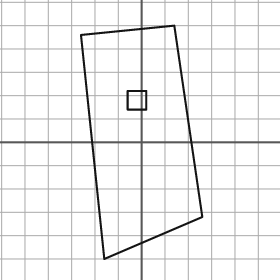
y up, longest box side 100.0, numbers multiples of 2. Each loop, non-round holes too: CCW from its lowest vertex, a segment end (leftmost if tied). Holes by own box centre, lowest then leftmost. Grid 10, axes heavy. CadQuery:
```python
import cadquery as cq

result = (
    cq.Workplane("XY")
    .moveTo(-16.0, -50.0)
    .lineTo(26.0, -32.0)
    .lineTo(14.0, 50.0)
    .lineTo(-26.0, 46.0)
    .close()
    .moveTo(-6.0, 14.0)
    .lineTo(2.0, 14.0)
    .lineTo(2.0, 22.0)
    .lineTo(-6.0, 22.0)
    .close()
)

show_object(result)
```